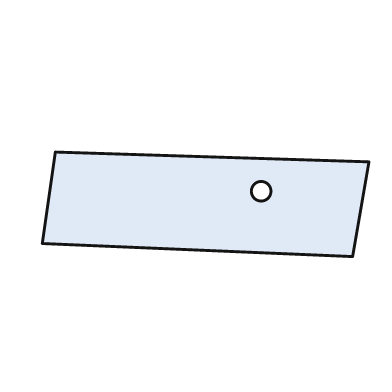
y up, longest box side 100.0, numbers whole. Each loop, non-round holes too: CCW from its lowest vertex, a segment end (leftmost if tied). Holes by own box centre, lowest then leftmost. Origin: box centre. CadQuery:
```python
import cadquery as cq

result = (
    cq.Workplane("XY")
    .moveTo(45.0, -16.0)
    .lineTo(50.0, 13.0)
    .lineTo(-46.0, 16.0)
    .lineTo(-50.0, -12.0)
    .close()
    .moveTo(17.0, 4.0)
    .circle(3.0)
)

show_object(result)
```